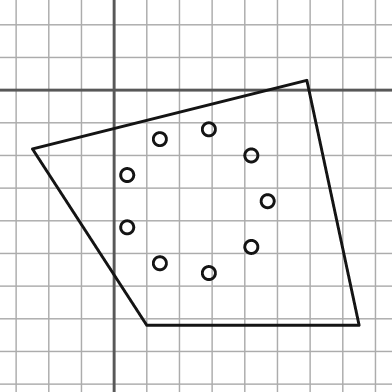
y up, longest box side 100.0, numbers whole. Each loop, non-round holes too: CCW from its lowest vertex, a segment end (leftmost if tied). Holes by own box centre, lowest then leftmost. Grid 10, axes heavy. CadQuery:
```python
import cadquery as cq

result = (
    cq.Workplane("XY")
    .moveTo(10.0, -72.0)
    .lineTo(75.0, -72.0)
    .lineTo(59.0, 3.0)
    .lineTo(-25.0, -18.0)
    .close()
    .moveTo(29.0, -56.0)
    .circle(2.0)
    .moveTo(14.0, -53.0)
    .circle(2.0)
    .moveTo(42.0, -48.0)
    .circle(2.0)
    .moveTo(4.0, -42.0)
    .circle(2.0)
    .moveTo(47.0, -34.0)
    .circle(2.0)
    .moveTo(4.0, -26.0)
    .circle(2.0)
    .moveTo(42.0, -20.0)
    .circle(2.0)
    .moveTo(14.0, -15.0)
    .circle(2.0)
    .moveTo(29.0, -12.0)
    .circle(2.0)
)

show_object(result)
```